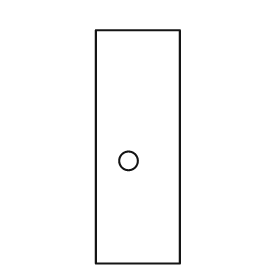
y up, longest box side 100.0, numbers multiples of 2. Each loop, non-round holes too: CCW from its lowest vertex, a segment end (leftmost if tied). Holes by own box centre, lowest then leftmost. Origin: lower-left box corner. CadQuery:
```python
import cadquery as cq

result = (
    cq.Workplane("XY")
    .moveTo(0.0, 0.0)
    .lineTo(36.0, 0.0)
    .lineTo(36.0, 100.0)
    .lineTo(0.0, 100.0)
    .close()
    .moveTo(14.0, 44.0)
    .circle(4.0)
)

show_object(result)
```